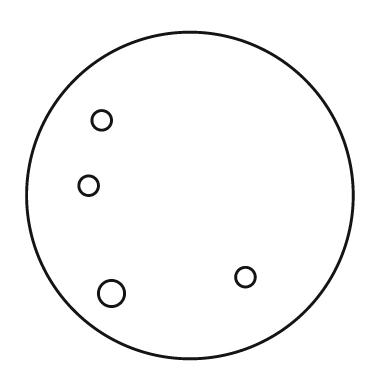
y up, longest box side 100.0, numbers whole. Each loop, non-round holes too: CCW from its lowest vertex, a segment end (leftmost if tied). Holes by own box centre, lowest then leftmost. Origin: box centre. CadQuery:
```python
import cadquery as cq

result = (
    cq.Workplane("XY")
    .moveTo(0.0, 0.0)
    .circle(50.0)
    .moveTo(-24.0, -30.0)
    .circle(4.0)
    .moveTo(17.0, -25.0)
    .circle(3.0)
    .moveTo(-31.0, 3.0)
    .circle(3.0)
    .moveTo(-27.0, 23.0)
    .circle(3.0)
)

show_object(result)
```